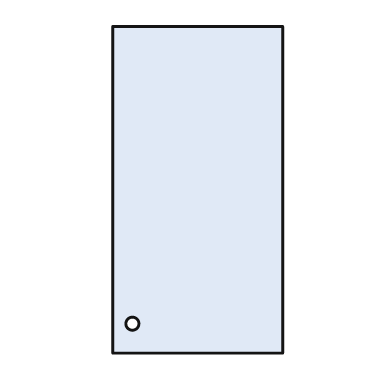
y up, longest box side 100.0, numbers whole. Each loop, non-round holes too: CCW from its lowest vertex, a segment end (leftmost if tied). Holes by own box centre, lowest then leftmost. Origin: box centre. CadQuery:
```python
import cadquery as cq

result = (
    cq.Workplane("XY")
    .moveTo(-26.0, -50.0)
    .lineTo(26.0, -50.0)
    .lineTo(26.0, 50.0)
    .lineTo(-26.0, 50.0)
    .close()
    .moveTo(-20.0, -41.0)
    .circle(2.0)
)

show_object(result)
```